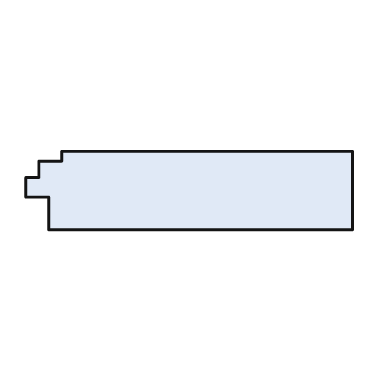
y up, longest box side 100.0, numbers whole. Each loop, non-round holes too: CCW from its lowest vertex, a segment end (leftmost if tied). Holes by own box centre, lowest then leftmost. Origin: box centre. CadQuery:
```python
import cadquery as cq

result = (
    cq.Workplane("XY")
    .moveTo(-43.0, -12.0)
    .lineTo(50.0, -12.0)
    .lineTo(50.0, 12.0)
    .lineTo(-39.0, 12.0)
    .lineTo(-39.0, 9.0)
    .lineTo(-46.0, 9.0)
    .lineTo(-46.0, 4.0)
    .lineTo(-50.0, 4.0)
    .lineTo(-50.0, -2.0)
    .lineTo(-43.0, -2.0)
    .close()
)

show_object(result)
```